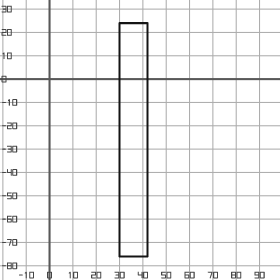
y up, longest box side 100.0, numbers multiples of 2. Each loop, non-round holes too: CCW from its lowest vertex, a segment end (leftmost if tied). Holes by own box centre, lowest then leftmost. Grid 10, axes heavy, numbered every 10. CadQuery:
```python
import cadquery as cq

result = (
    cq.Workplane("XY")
    .moveTo(30.0, -76.0)
    .lineTo(42.0, -76.0)
    .lineTo(42.0, 24.0)
    .lineTo(30.0, 24.0)
    .close()
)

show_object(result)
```